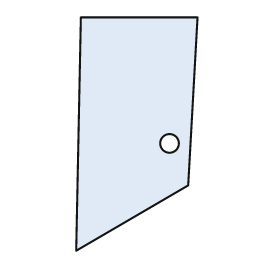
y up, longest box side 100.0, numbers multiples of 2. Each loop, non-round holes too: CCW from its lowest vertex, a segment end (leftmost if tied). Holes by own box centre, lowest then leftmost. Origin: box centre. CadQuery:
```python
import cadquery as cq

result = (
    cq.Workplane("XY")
    .moveTo(-26.0, -50.0)
    .lineTo(22.0, -22.0)
    .lineTo(26.0, 50.0)
    .lineTo(-24.0, 50.0)
    .close()
    .moveTo(14.0, -4.0)
    .circle(4.0)
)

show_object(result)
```